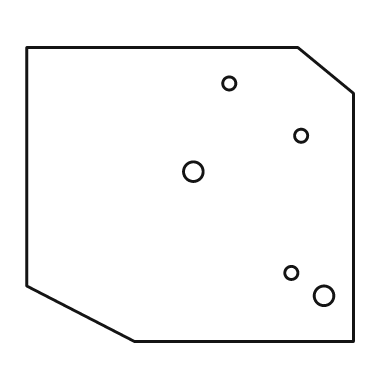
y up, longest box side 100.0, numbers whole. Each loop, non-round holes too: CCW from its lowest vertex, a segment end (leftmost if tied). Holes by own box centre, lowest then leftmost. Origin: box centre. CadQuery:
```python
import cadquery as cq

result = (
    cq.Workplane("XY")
    .moveTo(-17.0, -45.0)
    .lineTo(50.0, -45.0)
    .lineTo(50.0, 31.0)
    .lineTo(33.0, 45.0)
    .lineTo(-50.0, 45.0)
    .lineTo(-50.0, -28.0)
    .close()
    .moveTo(41.0, -31.0)
    .circle(3.0)
    .moveTo(31.0, -24.0)
    .circle(2.0)
    .moveTo(1.0, 7.0)
    .circle(3.0)
    .moveTo(34.0, 18.0)
    .circle(2.0)
    .moveTo(12.0, 34.0)
    .circle(2.0)
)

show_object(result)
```